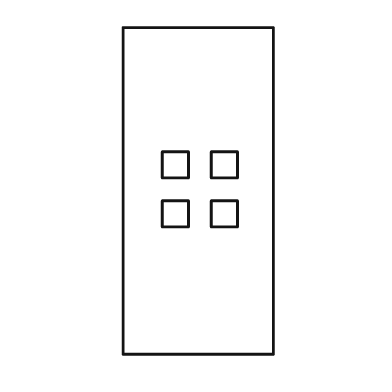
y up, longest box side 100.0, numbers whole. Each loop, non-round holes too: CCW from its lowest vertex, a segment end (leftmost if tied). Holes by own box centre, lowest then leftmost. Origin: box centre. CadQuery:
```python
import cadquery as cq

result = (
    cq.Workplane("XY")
    .moveTo(-23.0, -50.0)
    .lineTo(23.0, -50.0)
    .lineTo(23.0, 50.0)
    .lineTo(-23.0, 50.0)
    .close()
    .moveTo(-11.0, -11.0)
    .lineTo(-3.0, -11.0)
    .lineTo(-3.0, -3.0)
    .lineTo(-11.0, -3.0)
    .close()
    .moveTo(4.0, -11.0)
    .lineTo(12.0, -11.0)
    .lineTo(12.0, -3.0)
    .lineTo(4.0, -3.0)
    .close()
    .moveTo(-11.0, 4.0)
    .lineTo(-3.0, 4.0)
    .lineTo(-3.0, 12.0)
    .lineTo(-11.0, 12.0)
    .close()
    .moveTo(4.0, 4.0)
    .lineTo(12.0, 4.0)
    .lineTo(12.0, 12.0)
    .lineTo(4.0, 12.0)
    .close()
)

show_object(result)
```